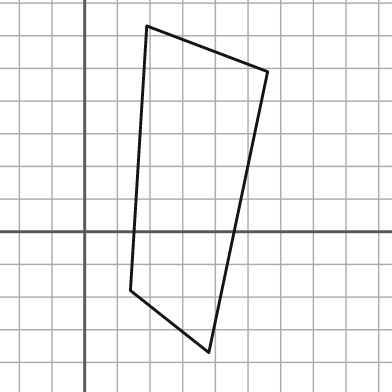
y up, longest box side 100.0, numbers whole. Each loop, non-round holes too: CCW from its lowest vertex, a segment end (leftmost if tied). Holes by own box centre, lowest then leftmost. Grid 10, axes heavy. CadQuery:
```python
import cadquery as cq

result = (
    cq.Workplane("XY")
    .moveTo(38.0, -37.0)
    .lineTo(56.0, 49.0)
    .lineTo(19.0, 63.0)
    .lineTo(14.0, -18.0)
    .close()
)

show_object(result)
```